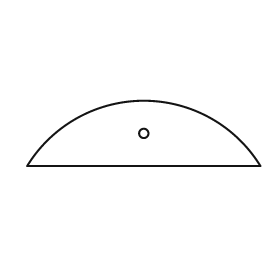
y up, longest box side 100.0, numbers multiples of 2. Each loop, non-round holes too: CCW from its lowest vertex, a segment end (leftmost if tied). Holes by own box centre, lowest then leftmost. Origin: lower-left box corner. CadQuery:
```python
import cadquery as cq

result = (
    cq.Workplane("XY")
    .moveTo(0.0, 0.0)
    .lineTo(100.0, 0.0)
    .threePointArc((50.0, 28.0), (0.0, 0.0))
    .close()
    .moveTo(50.0, 14.0)
    .circle(2.0)
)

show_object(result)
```